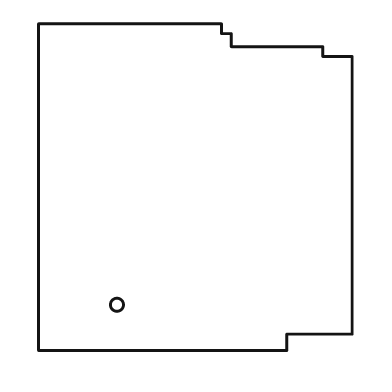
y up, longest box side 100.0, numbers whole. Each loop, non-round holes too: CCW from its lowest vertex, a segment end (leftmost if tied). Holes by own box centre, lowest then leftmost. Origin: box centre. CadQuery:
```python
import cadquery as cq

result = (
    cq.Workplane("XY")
    .moveTo(-48.0, -50.0)
    .lineTo(28.0, -50.0)
    .lineTo(28.0, -45.0)
    .lineTo(48.0, -45.0)
    .lineTo(48.0, 40.0)
    .lineTo(39.0, 40.0)
    .lineTo(39.0, 43.0)
    .lineTo(11.0, 43.0)
    .lineTo(11.0, 47.0)
    .lineTo(8.0, 47.0)
    .lineTo(8.0, 50.0)
    .lineTo(-48.0, 50.0)
    .close()
    .moveTo(-24.0, -36.0)
    .circle(2.0)
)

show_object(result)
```